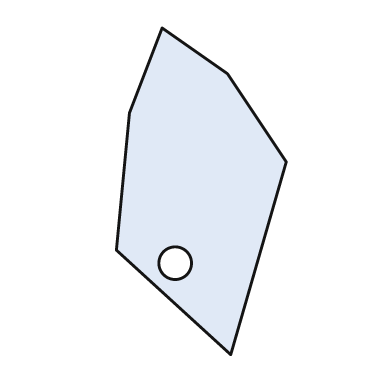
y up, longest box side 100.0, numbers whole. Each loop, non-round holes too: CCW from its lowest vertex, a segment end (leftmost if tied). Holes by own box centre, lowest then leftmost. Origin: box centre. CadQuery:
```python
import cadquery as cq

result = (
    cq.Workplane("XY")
    .moveTo(9.0, -50.0)
    .lineTo(26.0, 9.0)
    .lineTo(8.0, 36.0)
    .lineTo(-12.0, 50.0)
    .lineTo(-22.0, 24.0)
    .lineTo(-26.0, -18.0)
    .close()
    .moveTo(-8.0, -22.0)
    .circle(5.0)
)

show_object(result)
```